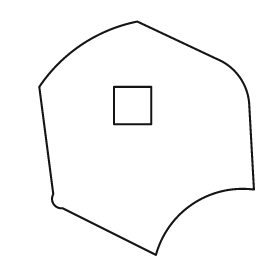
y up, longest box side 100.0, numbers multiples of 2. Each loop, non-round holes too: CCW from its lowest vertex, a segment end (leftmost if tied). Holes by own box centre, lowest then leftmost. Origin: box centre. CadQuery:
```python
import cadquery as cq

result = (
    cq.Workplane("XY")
    .moveTo(4.0, -50.0)
    .threePointArc((20.0, -28.0), (46.0, -22.0))
    .lineTo(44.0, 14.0)
    .threePointArc((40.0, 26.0), (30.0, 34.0))
    .lineTo(-4.0, 50.0)
    .threePointArc((-28.0, 40.0), (-46.0, 22.0))
    .lineTo(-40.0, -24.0)
    .threePointArc((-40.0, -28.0), (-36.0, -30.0))
    .close()
    .moveTo(-14.0, 6.0)
    .lineTo(2.0, 6.0)
    .lineTo(2.0, 22.0)
    .lineTo(-14.0, 22.0)
    .close()
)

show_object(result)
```